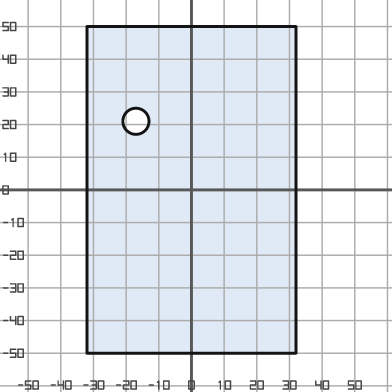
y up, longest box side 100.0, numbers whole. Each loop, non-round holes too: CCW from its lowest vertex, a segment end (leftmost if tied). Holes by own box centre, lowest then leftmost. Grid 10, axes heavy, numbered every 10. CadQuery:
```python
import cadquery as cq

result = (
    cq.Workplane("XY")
    .moveTo(-32.0, -50.0)
    .lineTo(32.0, -50.0)
    .lineTo(32.0, 50.0)
    .lineTo(-32.0, 50.0)
    .close()
    .moveTo(-17.0, 21.0)
    .circle(4.0)
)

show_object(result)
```